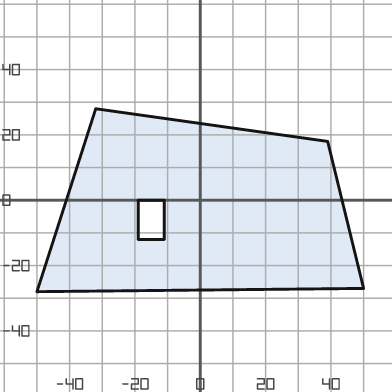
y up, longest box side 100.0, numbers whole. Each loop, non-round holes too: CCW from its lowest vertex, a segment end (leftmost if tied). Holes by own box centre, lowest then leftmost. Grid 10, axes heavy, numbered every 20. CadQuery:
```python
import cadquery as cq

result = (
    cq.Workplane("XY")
    .moveTo(-50.0, -28.0)
    .lineTo(50.0, -27.0)
    .lineTo(39.0, 18.0)
    .lineTo(-32.0, 28.0)
    .close()
    .moveTo(-19.0, -12.0)
    .lineTo(-11.0, -12.0)
    .lineTo(-11.0, 0.0)
    .lineTo(-19.0, 0.0)
    .close()
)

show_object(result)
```